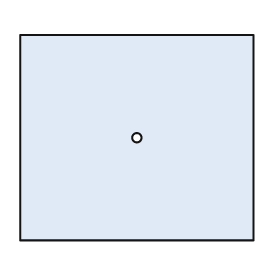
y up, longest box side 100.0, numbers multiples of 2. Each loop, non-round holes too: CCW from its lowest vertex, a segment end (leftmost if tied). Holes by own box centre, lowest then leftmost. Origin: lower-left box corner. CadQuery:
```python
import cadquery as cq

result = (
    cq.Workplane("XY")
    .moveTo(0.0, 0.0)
    .lineTo(100.0, 0.0)
    .lineTo(100.0, 88.0)
    .lineTo(0.0, 88.0)
    .close()
    .moveTo(50.0, 44.0)
    .circle(2.0)
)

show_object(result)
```